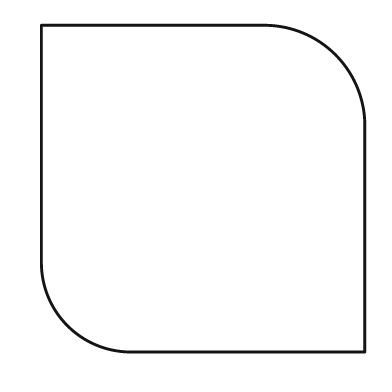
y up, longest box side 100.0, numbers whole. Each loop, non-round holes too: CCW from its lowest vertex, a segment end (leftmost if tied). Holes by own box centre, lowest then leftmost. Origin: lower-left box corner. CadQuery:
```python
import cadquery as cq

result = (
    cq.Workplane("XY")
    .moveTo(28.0, 0.0)
    .lineTo(99.0, 0.0)
    .lineTo(99.0, 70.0)
    .threePointArc((90.0, 91.0), (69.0, 100.0))
    .lineTo(0.0, 100.0)
    .lineTo(0.0, 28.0)
    .threePointArc((8.0, 8.0), (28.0, 0.0))
    .close()
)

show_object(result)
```